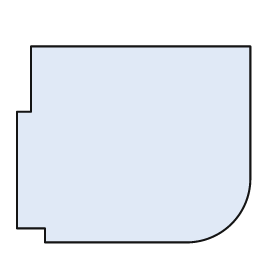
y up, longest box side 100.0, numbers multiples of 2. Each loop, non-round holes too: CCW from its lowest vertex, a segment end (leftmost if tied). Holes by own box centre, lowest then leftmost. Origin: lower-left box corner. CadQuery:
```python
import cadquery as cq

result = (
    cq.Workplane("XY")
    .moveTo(12.0, 0.0)
    .lineTo(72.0, 0.0)
    .threePointArc((92.0, 8.0), (100.0, 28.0))
    .lineTo(100.0, 84.0)
    .lineTo(6.0, 84.0)
    .lineTo(6.0, 56.0)
    .lineTo(0.0, 56.0)
    .lineTo(0.0, 6.0)
    .lineTo(12.0, 6.0)
    .close()
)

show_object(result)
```